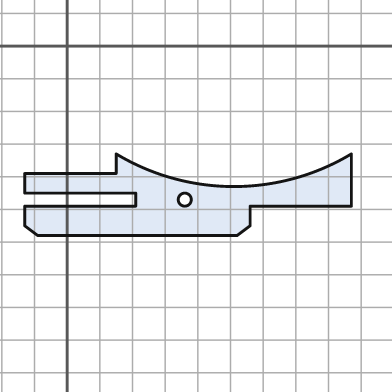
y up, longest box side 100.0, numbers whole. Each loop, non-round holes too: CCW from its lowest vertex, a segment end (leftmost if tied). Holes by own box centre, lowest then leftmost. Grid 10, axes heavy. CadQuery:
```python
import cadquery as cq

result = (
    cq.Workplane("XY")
    .moveTo(-9.0, -58.0)
    .lineTo(52.0, -58.0)
    .lineTo(56.0, -55.0)
    .lineTo(56.0, -49.0)
    .lineTo(87.0, -49.0)
    .lineTo(87.0, -33.0)
    .threePointArc((51.0, -43.0), (15.0, -33.0))
    .lineTo(15.0, -39.0)
    .lineTo(-13.0, -39.0)
    .lineTo(-13.0, -45.0)
    .lineTo(21.0, -45.0)
    .lineTo(21.0, -49.0)
    .lineTo(-13.0, -49.0)
    .lineTo(-13.0, -55.0)
    .close()
    .moveTo(36.0, -47.0)
    .circle(2.0)
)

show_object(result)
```